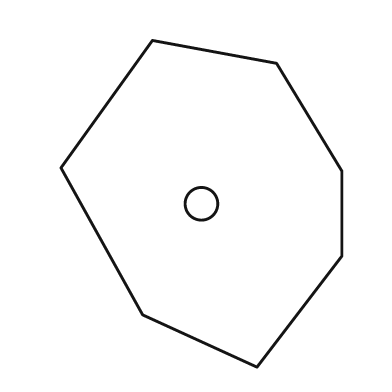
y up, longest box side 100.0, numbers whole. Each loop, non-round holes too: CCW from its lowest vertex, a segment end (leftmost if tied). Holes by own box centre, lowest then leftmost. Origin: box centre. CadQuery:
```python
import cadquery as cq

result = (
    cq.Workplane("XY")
    .moveTo(17.0, -50.0)
    .lineTo(43.0, -16.0)
    .lineTo(43.0, 10.0)
    .lineTo(23.0, 43.0)
    .lineTo(-15.0, 50.0)
    .lineTo(-43.0, 11.0)
    .lineTo(-18.0, -34.0)
    .close()
    .moveTo(0.0, 0.0)
    .circle(5.0)
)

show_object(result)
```